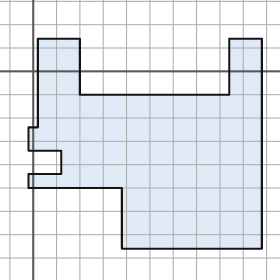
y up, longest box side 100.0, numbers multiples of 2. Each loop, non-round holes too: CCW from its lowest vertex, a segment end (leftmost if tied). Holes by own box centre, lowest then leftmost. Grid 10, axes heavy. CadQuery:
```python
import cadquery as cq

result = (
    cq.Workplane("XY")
    .moveTo(38.0, -76.0)
    .lineTo(98.0, -76.0)
    .lineTo(98.0, 14.0)
    .lineTo(84.0, 14.0)
    .lineTo(84.0, -10.0)
    .lineTo(20.0, -10.0)
    .lineTo(20.0, 14.0)
    .lineTo(2.0, 14.0)
    .lineTo(2.0, -24.0)
    .lineTo(-2.0, -24.0)
    .lineTo(-2.0, -34.0)
    .lineTo(12.0, -34.0)
    .lineTo(12.0, -44.0)
    .lineTo(-2.0, -44.0)
    .lineTo(-2.0, -50.0)
    .lineTo(38.0, -50.0)
    .close()
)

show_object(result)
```